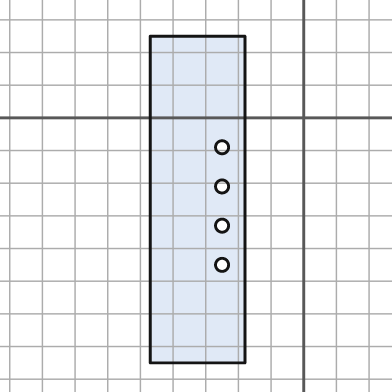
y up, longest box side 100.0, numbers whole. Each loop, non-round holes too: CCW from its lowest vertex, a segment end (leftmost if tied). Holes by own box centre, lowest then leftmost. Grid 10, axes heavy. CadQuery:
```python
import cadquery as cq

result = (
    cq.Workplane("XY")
    .moveTo(-47.0, -75.0)
    .lineTo(-18.0, -75.0)
    .lineTo(-18.0, 25.0)
    .lineTo(-47.0, 25.0)
    .close()
    .moveTo(-25.0, -45.0)
    .circle(2.0)
    .moveTo(-25.0, -33.0)
    .circle(2.0)
    .moveTo(-25.0, -21.0)
    .circle(2.0)
    .moveTo(-25.0, -9.0)
    .circle(2.0)
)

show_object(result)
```